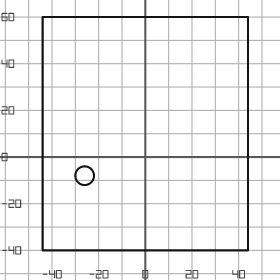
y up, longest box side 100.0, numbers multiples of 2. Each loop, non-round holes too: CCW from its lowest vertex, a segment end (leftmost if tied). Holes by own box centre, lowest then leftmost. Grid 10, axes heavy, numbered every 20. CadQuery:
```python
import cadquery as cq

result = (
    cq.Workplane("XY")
    .moveTo(-44.0, -40.0)
    .lineTo(44.0, -40.0)
    .lineTo(44.0, 60.0)
    .lineTo(-44.0, 60.0)
    .close()
    .moveTo(-26.0, -8.0)
    .circle(4.0)
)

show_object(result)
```